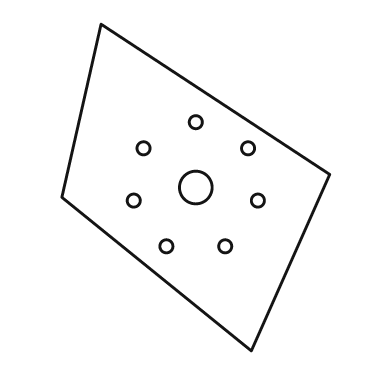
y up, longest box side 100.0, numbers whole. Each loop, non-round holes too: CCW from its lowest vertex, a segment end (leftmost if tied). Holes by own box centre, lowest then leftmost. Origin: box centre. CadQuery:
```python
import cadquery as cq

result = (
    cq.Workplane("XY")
    .moveTo(17.0, -50.0)
    .lineTo(41.0, 4.0)
    .lineTo(-29.0, 50.0)
    .lineTo(-41.0, -3.0)
    .close()
    .moveTo(-9.0, -18.0)
    .circle(2.0)
    .moveTo(9.0, -18.0)
    .circle(2.0)
    .moveTo(-19.0, -4.0)
    .circle(2.0)
    .moveTo(19.0, -4.0)
    .circle(2.0)
    .moveTo(0.0, 0.0)
    .circle(5.0)
    .moveTo(-16.0, 12.0)
    .circle(2.0)
    .moveTo(16.0, 12.0)
    .circle(2.0)
    .moveTo(0.0, 20.0)
    .circle(2.0)
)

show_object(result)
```